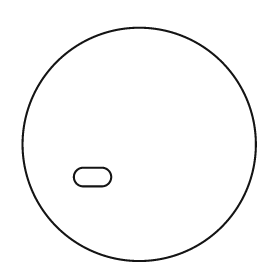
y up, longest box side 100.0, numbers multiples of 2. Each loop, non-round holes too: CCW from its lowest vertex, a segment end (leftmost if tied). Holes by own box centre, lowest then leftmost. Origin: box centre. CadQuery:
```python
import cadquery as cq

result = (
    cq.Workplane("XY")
    .moveTo(0.0, 0.0)
    .circle(50.0)
    .moveTo(-24.0, -18.0)
    .lineTo(-16.0, -18.0)
    .threePointArc((-12.0, -14.0), (-16.0, -10.0))
    .lineTo(-24.0, -10.0)
    .threePointArc((-28.0, -14.0), (-24.0, -18.0))
    .close()
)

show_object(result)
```